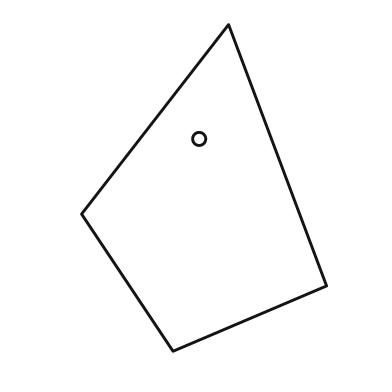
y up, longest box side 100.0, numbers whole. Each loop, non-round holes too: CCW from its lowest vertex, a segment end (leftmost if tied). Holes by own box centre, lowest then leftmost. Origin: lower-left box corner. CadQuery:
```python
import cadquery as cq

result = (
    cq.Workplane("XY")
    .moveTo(28.0, 0.0)
    .lineTo(75.0, 20.0)
    .lineTo(45.0, 100.0)
    .lineTo(0.0, 42.0)
    .close()
    .moveTo(36.0, 65.0)
    .circle(2.0)
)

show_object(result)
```